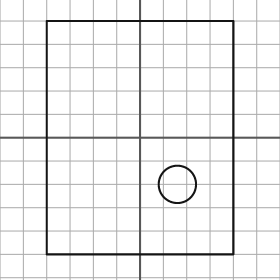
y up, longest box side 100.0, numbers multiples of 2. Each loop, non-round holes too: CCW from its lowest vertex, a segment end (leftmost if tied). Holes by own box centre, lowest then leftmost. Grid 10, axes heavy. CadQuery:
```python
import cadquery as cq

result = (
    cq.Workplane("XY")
    .moveTo(-40.0, -50.0)
    .lineTo(40.0, -50.0)
    .lineTo(40.0, 50.0)
    .lineTo(-40.0, 50.0)
    .close()
    .moveTo(16.0, -20.0)
    .circle(8.0)
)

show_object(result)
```